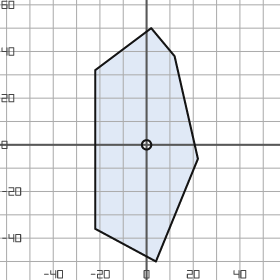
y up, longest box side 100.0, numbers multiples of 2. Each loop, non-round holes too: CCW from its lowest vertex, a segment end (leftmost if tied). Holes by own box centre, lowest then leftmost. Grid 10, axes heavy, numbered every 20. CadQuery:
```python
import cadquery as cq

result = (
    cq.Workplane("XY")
    .moveTo(4.0, -50.0)
    .lineTo(22.0, -6.0)
    .lineTo(12.0, 38.0)
    .lineTo(2.0, 50.0)
    .lineTo(-22.0, 32.0)
    .lineTo(-22.0, -36.0)
    .close()
    .moveTo(0.0, 0.0)
    .circle(2.0)
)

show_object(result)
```